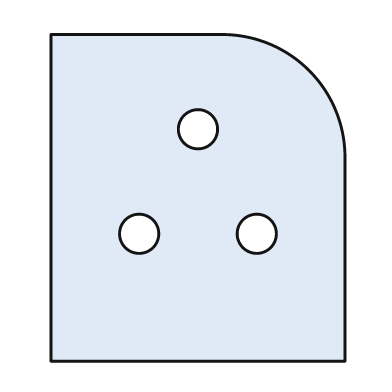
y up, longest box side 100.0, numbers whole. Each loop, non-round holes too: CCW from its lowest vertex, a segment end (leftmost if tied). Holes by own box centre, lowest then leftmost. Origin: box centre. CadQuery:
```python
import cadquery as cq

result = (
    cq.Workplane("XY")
    .moveTo(-45.0, -50.0)
    .lineTo(45.0, -50.0)
    .lineTo(45.0, 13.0)
    .threePointArc((34.0, 39.0), (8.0, 50.0))
    .lineTo(-45.0, 50.0)
    .close()
    .moveTo(-18.0, -11.0)
    .circle(6.0)
    .moveTo(18.0, -11.0)
    .circle(6.0)
    .moveTo(0.0, 21.0)
    .circle(6.0)
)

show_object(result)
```